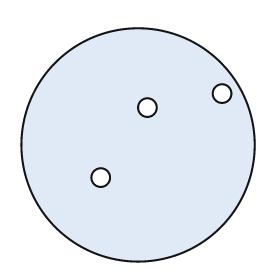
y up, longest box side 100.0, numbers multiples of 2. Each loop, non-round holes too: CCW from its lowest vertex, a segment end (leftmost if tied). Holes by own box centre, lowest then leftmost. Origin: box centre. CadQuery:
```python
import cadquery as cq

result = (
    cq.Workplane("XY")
    .moveTo(0.0, 0.0)
    .circle(50.0)
    .moveTo(-16.0, -14.0)
    .circle(4.0)
    .moveTo(4.0, 16.0)
    .circle(4.0)
    .moveTo(36.0, 22.0)
    .circle(4.0)
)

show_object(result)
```